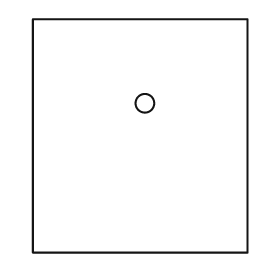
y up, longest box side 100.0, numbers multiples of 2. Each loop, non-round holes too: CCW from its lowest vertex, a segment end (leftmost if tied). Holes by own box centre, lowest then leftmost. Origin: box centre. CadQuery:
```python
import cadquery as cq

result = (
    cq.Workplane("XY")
    .moveTo(-46.0, -50.0)
    .lineTo(46.0, -50.0)
    .lineTo(46.0, 50.0)
    .lineTo(-46.0, 50.0)
    .close()
    .moveTo(2.0, 14.0)
    .circle(4.0)
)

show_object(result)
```